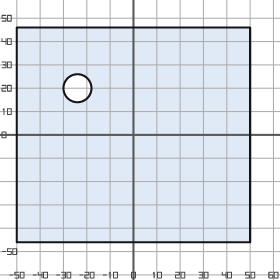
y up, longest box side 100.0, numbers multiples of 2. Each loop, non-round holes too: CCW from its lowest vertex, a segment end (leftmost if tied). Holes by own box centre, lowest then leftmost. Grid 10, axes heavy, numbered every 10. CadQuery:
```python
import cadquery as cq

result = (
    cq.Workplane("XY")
    .moveTo(-50.0, -46.0)
    .lineTo(50.0, -46.0)
    .lineTo(50.0, 46.0)
    .lineTo(-50.0, 46.0)
    .close()
    .moveTo(-24.0, 20.0)
    .circle(6.0)
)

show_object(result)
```